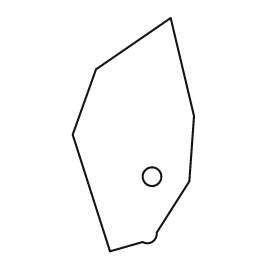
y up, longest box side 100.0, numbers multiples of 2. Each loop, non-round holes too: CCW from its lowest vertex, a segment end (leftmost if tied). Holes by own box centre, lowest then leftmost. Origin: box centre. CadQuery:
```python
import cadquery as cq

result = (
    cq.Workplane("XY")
    .moveTo(-10.0, -50.0)
    .lineTo(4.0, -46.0)
    .threePointArc((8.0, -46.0), (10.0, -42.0))
    .lineTo(24.0, -20.0)
    .lineTo(26.0, 8.0)
    .lineTo(16.0, 50.0)
    .lineTo(-16.0, 28.0)
    .lineTo(-26.0, 0.0)
    .close()
    .moveTo(8.0, -18.0)
    .circle(4.0)
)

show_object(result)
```